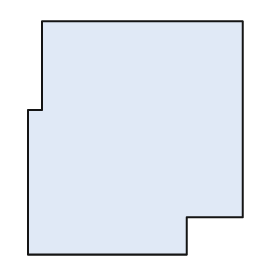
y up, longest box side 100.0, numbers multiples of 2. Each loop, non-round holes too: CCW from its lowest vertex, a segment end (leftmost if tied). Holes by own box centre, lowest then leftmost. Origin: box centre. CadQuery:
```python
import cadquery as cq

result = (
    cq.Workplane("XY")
    .moveTo(-46.0, -50.0)
    .lineTo(22.0, -50.0)
    .lineTo(22.0, -34.0)
    .lineTo(46.0, -34.0)
    .lineTo(46.0, 50.0)
    .lineTo(-40.0, 50.0)
    .lineTo(-40.0, 12.0)
    .lineTo(-46.0, 12.0)
    .close()
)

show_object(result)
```